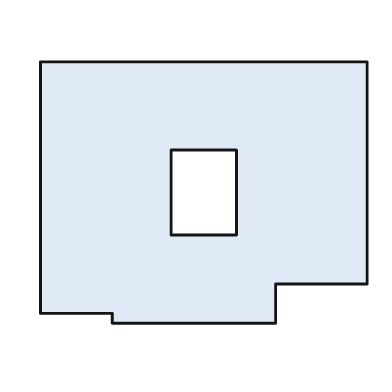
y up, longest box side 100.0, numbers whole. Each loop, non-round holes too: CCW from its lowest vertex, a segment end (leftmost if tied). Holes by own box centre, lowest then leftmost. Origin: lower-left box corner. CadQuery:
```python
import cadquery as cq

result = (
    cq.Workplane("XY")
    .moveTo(22.0, 0.0)
    .lineTo(72.0, 0.0)
    .lineTo(72.0, 12.0)
    .lineTo(100.0, 12.0)
    .lineTo(100.0, 80.0)
    .lineTo(0.0, 80.0)
    .lineTo(0.0, 3.0)
    .lineTo(22.0, 3.0)
    .close()
    .moveTo(40.0, 27.0)
    .lineTo(60.0, 27.0)
    .lineTo(60.0, 53.0)
    .lineTo(40.0, 53.0)
    .close()
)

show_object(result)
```